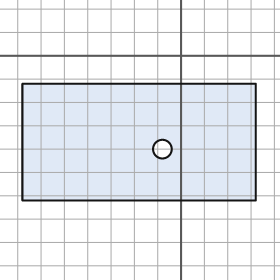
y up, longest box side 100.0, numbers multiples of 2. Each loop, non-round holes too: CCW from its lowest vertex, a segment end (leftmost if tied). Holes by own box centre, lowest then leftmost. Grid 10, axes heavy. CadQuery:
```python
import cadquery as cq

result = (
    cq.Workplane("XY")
    .moveTo(-68.0, -62.0)
    .lineTo(32.0, -62.0)
    .lineTo(32.0, -12.0)
    .lineTo(-68.0, -12.0)
    .close()
    .moveTo(-8.0, -40.0)
    .circle(4.0)
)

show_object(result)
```